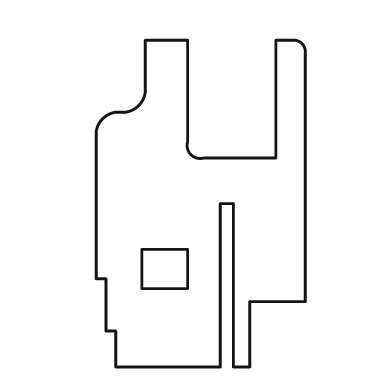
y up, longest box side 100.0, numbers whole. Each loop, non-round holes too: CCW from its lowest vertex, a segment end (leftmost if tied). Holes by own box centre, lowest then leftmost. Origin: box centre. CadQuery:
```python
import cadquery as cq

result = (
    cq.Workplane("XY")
    .moveTo(-26.0, -50.0)
    .lineTo(6.0, -50.0)
    .lineTo(6.0, 0.0)
    .lineTo(10.0, 0.0)
    .lineTo(10.0, -50.0)
    .lineTo(15.0, -50.0)
    .lineTo(15.0, -30.0)
    .lineTo(32.0, -30.0)
    .lineTo(32.0, 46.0)
    .threePointArc((31.0, 49.0), (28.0, 50.0))
    .lineTo(23.0, 50.0)
    .lineTo(23.0, 14.0)
    .lineTo(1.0, 14.0)
    .threePointArc((-3.0, 15.0), (-4.0, 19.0))
    .lineTo(-4.0, 50.0)
    .lineTo(-17.0, 50.0)
    .lineTo(-17.0, 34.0)
    .threePointArc((-19.0, 30.0), (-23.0, 28.0))
    .lineTo(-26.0, 28.0)
    .threePointArc((-30.0, 26.0), (-32.0, 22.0))
    .lineTo(-32.0, -23.0)
    .lineTo(-29.0, -23.0)
    .lineTo(-29.0, -39.0)
    .lineTo(-26.0, -39.0)
    .close()
    .moveTo(-18.0, -26.0)
    .lineTo(-4.0, -26.0)
    .lineTo(-4.0, -14.0)
    .lineTo(-18.0, -14.0)
    .close()
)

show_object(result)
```